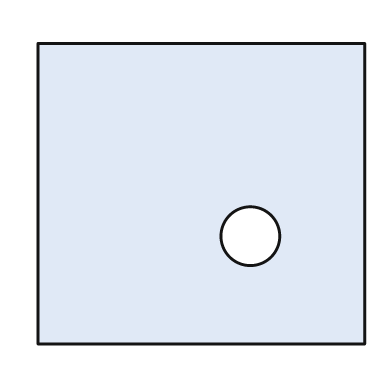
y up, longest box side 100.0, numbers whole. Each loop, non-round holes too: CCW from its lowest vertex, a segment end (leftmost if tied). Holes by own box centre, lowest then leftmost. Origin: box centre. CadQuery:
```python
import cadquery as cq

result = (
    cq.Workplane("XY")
    .moveTo(-50.0, -46.0)
    .lineTo(50.0, -46.0)
    .lineTo(50.0, 46.0)
    .lineTo(-50.0, 46.0)
    .close()
    .moveTo(15.0, -13.0)
    .circle(9.0)
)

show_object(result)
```